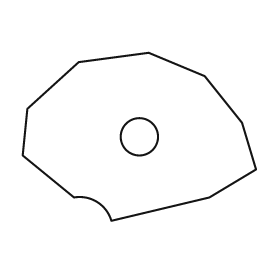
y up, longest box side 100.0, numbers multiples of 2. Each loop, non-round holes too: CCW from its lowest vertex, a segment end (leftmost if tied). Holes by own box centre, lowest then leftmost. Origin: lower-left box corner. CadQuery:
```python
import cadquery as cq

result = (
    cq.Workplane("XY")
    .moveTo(38.0, 0.0)
    .lineTo(80.0, 10.0)
    .lineTo(100.0, 22.0)
    .lineTo(94.0, 42.0)
    .lineTo(78.0, 62.0)
    .lineTo(54.0, 72.0)
    .lineTo(24.0, 68.0)
    .lineTo(2.0, 48.0)
    .lineTo(0.0, 28.0)
    .lineTo(22.0, 10.0)
    .threePointArc((32.0, 8.0), (38.0, 0.0))
    .close()
    .moveTo(50.0, 36.0)
    .circle(8.0)
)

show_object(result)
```